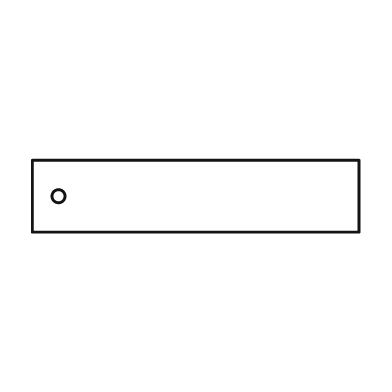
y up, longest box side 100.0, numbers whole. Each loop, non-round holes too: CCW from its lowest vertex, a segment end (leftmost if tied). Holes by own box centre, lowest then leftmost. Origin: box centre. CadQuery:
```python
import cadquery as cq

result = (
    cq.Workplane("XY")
    .moveTo(-50.0, -11.0)
    .lineTo(50.0, -11.0)
    .lineTo(50.0, 11.0)
    .lineTo(-50.0, 11.0)
    .close()
    .moveTo(-42.0, 0.0)
    .circle(2.0)
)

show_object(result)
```